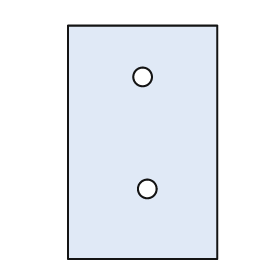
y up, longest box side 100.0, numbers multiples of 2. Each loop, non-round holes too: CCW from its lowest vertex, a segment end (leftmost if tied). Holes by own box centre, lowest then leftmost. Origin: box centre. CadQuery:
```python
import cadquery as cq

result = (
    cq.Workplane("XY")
    .moveTo(-32.0, -50.0)
    .lineTo(32.0, -50.0)
    .lineTo(32.0, 50.0)
    .lineTo(-32.0, 50.0)
    .close()
    .moveTo(2.0, -20.0)
    .circle(4.0)
    .moveTo(0.0, 28.0)
    .circle(4.0)
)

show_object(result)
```